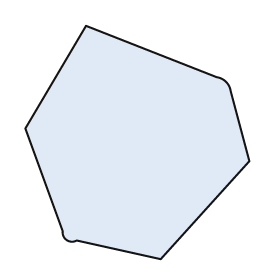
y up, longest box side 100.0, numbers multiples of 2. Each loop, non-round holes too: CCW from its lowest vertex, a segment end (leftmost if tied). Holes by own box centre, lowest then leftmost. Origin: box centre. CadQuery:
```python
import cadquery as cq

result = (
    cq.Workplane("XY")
    .moveTo(10.0, -50.0)
    .lineTo(48.0, -8.0)
    .lineTo(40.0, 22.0)
    .threePointArc((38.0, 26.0), (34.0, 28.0))
    .lineTo(-22.0, 50.0)
    .lineTo(-48.0, 6.0)
    .lineTo(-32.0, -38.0)
    .threePointArc((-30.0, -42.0), (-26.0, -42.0))
    .close()
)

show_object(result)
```